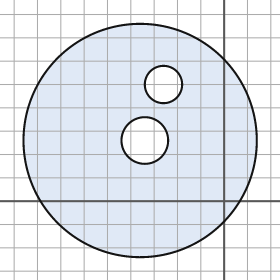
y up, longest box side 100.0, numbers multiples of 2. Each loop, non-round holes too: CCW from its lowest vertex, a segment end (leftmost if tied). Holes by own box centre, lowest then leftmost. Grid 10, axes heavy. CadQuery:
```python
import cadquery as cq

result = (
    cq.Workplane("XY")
    .moveTo(-36.0, 26.0)
    .circle(50.0)
    .moveTo(-34.0, 26.0)
    .circle(10.0)
    .moveTo(-26.0, 50.0)
    .circle(8.0)
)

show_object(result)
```